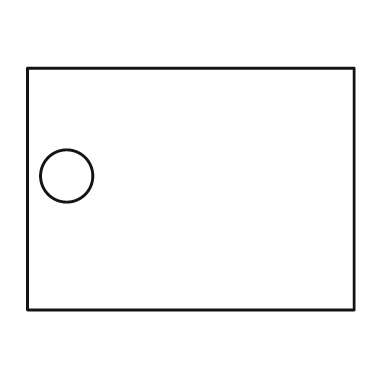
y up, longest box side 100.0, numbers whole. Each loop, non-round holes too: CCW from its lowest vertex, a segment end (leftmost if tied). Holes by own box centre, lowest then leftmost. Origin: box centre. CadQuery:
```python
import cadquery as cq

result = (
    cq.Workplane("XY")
    .moveTo(-50.0, -37.0)
    .lineTo(50.0, -37.0)
    .lineTo(50.0, 37.0)
    .lineTo(-50.0, 37.0)
    .close()
    .moveTo(-38.0, 4.0)
    .circle(8.0)
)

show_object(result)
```